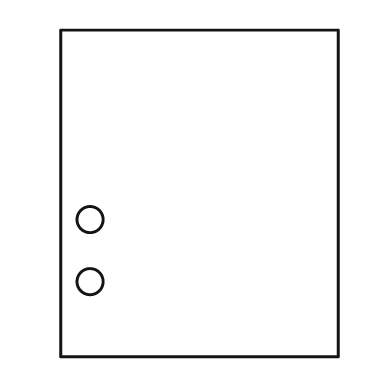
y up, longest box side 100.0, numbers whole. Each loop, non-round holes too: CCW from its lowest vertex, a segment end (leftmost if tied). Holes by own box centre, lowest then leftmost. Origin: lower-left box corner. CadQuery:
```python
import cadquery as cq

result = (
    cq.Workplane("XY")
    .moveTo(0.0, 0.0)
    .lineTo(85.0, 0.0)
    .lineTo(85.0, 100.0)
    .lineTo(0.0, 100.0)
    .close()
    .moveTo(9.0, 23.0)
    .circle(4.0)
    .moveTo(9.0, 42.0)
    .circle(4.0)
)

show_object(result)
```